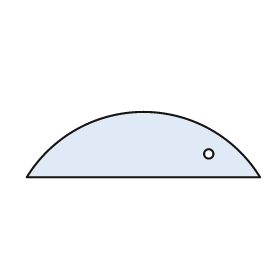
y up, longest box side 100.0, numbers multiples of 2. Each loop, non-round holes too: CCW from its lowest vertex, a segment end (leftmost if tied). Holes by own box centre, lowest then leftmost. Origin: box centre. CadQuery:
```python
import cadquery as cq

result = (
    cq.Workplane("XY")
    .moveTo(-50.0, -14.0)
    .lineTo(50.0, -14.0)
    .threePointArc((0.0, 14.0), (-50.0, -14.0))
    .close()
    .moveTo(28.0, -4.0)
    .circle(2.0)
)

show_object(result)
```